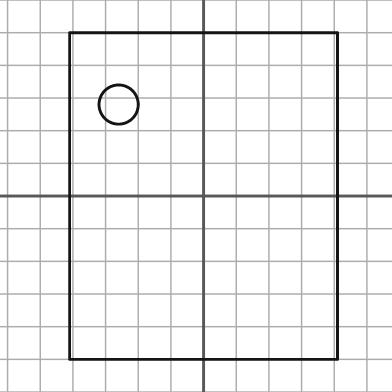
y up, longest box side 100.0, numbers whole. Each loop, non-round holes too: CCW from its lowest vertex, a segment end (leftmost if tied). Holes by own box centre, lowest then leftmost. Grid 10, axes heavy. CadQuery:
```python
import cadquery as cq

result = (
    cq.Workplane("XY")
    .moveTo(-41.0, -50.0)
    .lineTo(41.0, -50.0)
    .lineTo(41.0, 50.0)
    .lineTo(-41.0, 50.0)
    .close()
    .moveTo(-26.0, 28.0)
    .circle(6.0)
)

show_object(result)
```